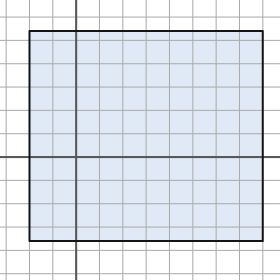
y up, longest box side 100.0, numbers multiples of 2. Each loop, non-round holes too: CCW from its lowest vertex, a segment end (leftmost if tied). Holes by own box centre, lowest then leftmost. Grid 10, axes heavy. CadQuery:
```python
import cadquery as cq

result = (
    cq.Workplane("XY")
    .moveTo(-20.0, -36.0)
    .lineTo(80.0, -36.0)
    .lineTo(80.0, 54.0)
    .lineTo(-20.0, 54.0)
    .close()
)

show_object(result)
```